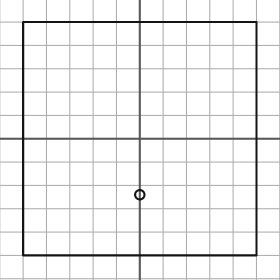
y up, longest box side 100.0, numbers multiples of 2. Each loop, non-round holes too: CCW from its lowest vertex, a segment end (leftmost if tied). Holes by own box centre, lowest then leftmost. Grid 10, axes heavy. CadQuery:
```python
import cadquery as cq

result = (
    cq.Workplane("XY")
    .moveTo(-50.0, -50.0)
    .lineTo(50.0, -50.0)
    .lineTo(50.0, 50.0)
    .lineTo(-50.0, 50.0)
    .close()
    .moveTo(0.0, -24.0)
    .circle(2.0)
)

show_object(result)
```